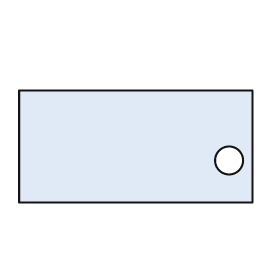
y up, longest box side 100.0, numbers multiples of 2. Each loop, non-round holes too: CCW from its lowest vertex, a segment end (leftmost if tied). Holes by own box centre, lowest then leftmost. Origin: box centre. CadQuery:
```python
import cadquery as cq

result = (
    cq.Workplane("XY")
    .moveTo(-50.0, -24.0)
    .lineTo(50.0, -24.0)
    .lineTo(50.0, 24.0)
    .lineTo(-50.0, 24.0)
    .close()
    .moveTo(40.0, -6.0)
    .circle(6.0)
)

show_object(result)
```